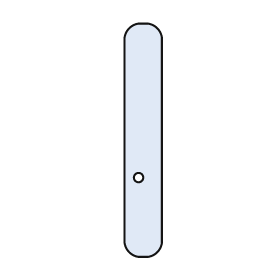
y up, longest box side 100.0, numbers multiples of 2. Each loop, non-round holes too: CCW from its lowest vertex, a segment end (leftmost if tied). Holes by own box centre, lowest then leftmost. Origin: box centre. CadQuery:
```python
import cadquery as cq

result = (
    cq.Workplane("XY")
    .moveTo(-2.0, -50.0)
    .lineTo(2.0, -50.0)
    .threePointArc((6.0, -48.0), (8.0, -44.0))
    .lineTo(8.0, 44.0)
    .threePointArc((6.0, 48.0), (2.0, 50.0))
    .lineTo(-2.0, 50.0)
    .threePointArc((-6.0, 48.0), (-8.0, 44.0))
    .lineTo(-8.0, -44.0)
    .threePointArc((-6.0, -48.0), (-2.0, -50.0))
    .close()
    .moveTo(-2.0, -16.0)
    .circle(2.0)
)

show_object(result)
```